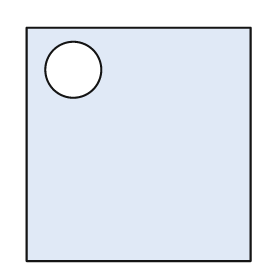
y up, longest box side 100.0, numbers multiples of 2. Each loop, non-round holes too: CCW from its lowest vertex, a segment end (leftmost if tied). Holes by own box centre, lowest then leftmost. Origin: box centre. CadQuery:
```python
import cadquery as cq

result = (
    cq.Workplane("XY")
    .moveTo(-48.0, -50.0)
    .lineTo(48.0, -50.0)
    .lineTo(48.0, 50.0)
    .lineTo(-48.0, 50.0)
    .close()
    .moveTo(-28.0, 32.0)
    .circle(12.0)
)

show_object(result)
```